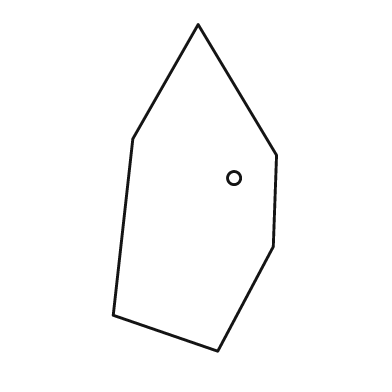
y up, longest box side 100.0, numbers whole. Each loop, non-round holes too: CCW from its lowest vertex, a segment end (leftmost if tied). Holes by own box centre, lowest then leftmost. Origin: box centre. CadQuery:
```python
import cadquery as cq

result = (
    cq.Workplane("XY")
    .moveTo(7.0, -50.0)
    .lineTo(24.0, -18.0)
    .lineTo(25.0, 10.0)
    .lineTo(1.0, 50.0)
    .lineTo(-19.0, 15.0)
    .lineTo(-25.0, -39.0)
    .close()
    .moveTo(12.0, 3.0)
    .circle(2.0)
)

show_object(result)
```